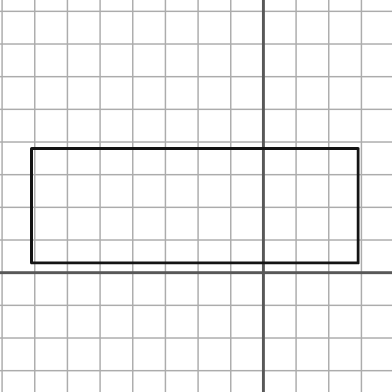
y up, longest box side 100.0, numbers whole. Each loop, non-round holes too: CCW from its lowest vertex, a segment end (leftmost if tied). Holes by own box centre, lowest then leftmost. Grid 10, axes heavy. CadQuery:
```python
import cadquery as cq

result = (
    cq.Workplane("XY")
    .moveTo(-71.0, 3.0)
    .lineTo(29.0, 3.0)
    .lineTo(29.0, 38.0)
    .lineTo(-71.0, 38.0)
    .close()
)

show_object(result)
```